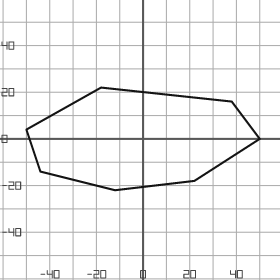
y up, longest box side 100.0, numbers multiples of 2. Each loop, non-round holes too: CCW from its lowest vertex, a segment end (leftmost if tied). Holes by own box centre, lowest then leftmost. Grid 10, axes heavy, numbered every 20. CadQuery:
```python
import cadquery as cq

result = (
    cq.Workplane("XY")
    .moveTo(-12.0, -22.0)
    .lineTo(22.0, -18.0)
    .lineTo(50.0, 0.0)
    .lineTo(38.0, 16.0)
    .lineTo(-18.0, 22.0)
    .lineTo(-50.0, 4.0)
    .lineTo(-44.0, -14.0)
    .close()
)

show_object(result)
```